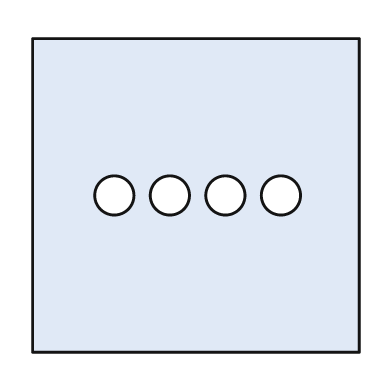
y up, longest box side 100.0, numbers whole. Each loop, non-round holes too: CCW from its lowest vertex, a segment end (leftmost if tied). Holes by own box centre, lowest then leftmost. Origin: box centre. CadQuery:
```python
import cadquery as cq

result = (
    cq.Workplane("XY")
    .moveTo(-50.0, -48.0)
    .lineTo(50.0, -48.0)
    .lineTo(50.0, 48.0)
    .lineTo(-50.0, 48.0)
    .close()
    .moveTo(-25.0, 0.0)
    .circle(6.0)
    .moveTo(-8.0, 0.0)
    .circle(6.0)
    .moveTo(9.0, 0.0)
    .circle(6.0)
    .moveTo(26.0, 0.0)
    .circle(6.0)
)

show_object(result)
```